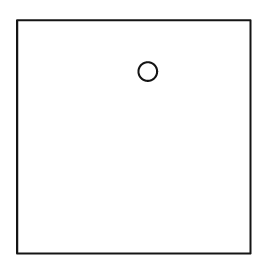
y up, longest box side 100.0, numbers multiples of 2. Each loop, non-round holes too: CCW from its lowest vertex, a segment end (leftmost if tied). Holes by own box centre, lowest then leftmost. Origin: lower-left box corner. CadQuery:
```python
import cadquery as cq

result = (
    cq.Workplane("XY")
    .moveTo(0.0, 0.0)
    .lineTo(100.0, 0.0)
    .lineTo(100.0, 100.0)
    .lineTo(0.0, 100.0)
    .close()
    .moveTo(56.0, 78.0)
    .circle(4.0)
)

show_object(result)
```